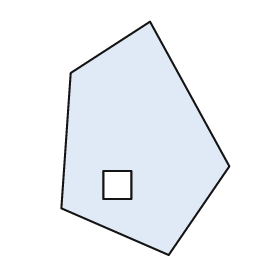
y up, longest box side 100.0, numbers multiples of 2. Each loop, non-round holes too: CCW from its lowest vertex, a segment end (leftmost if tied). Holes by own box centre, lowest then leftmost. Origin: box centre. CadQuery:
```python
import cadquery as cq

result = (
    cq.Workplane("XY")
    .moveTo(10.0, -50.0)
    .lineTo(36.0, -12.0)
    .lineTo(2.0, 50.0)
    .lineTo(-32.0, 28.0)
    .lineTo(-36.0, -30.0)
    .close()
    .moveTo(-18.0, -26.0)
    .lineTo(-6.0, -26.0)
    .lineTo(-6.0, -14.0)
    .lineTo(-18.0, -14.0)
    .close()
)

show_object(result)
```